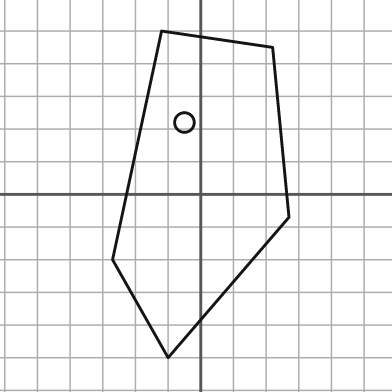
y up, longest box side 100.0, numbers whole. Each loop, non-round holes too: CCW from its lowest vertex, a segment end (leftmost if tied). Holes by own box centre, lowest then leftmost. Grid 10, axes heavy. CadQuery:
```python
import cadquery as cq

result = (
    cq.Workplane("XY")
    .moveTo(-10.0, -50.0)
    .lineTo(27.0, -7.0)
    .lineTo(22.0, 45.0)
    .lineTo(-12.0, 50.0)
    .lineTo(-27.0, -20.0)
    .close()
    .moveTo(-5.0, 22.0)
    .circle(3.0)
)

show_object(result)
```